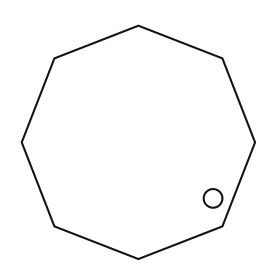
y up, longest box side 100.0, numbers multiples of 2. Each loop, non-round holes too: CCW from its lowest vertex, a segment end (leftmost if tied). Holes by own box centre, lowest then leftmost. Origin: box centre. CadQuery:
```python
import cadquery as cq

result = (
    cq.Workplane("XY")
    .moveTo(0.0, -50.0)
    .lineTo(36.0, -36.0)
    .lineTo(50.0, 0.0)
    .lineTo(36.0, 36.0)
    .lineTo(0.0, 50.0)
    .lineTo(-36.0, 36.0)
    .lineTo(-50.0, 0.0)
    .lineTo(-36.0, -36.0)
    .close()
    .moveTo(32.0, -24.0)
    .circle(4.0)
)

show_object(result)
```